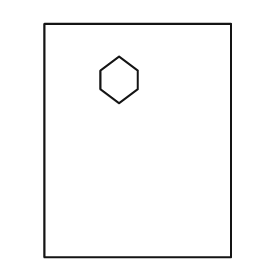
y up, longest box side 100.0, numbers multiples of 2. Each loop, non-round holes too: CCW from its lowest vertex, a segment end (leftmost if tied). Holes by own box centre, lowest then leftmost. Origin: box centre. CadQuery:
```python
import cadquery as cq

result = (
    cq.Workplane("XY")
    .moveTo(-40.0, -50.0)
    .lineTo(40.0, -50.0)
    .lineTo(40.0, 50.0)
    .lineTo(-40.0, 50.0)
    .close()
    .moveTo(-8.0, 16.0)
    .lineTo(0.0, 22.0)
    .lineTo(0.0, 30.0)
    .lineTo(-8.0, 36.0)
    .lineTo(-16.0, 30.0)
    .lineTo(-16.0, 22.0)
    .close()
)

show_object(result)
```